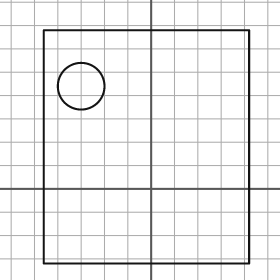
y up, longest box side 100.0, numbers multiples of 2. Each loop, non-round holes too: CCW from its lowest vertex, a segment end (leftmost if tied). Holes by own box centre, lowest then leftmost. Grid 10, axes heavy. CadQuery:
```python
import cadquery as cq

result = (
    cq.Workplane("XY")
    .moveTo(-46.0, -32.0)
    .lineTo(42.0, -32.0)
    .lineTo(42.0, 68.0)
    .lineTo(-46.0, 68.0)
    .close()
    .moveTo(-30.0, 44.0)
    .circle(10.0)
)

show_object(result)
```